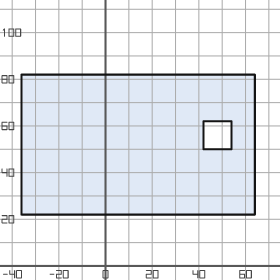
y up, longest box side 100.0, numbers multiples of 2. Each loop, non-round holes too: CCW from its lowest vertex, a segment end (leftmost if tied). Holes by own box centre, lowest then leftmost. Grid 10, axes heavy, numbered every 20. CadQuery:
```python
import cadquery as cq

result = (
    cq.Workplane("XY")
    .moveTo(-36.0, 22.0)
    .lineTo(64.0, 22.0)
    .lineTo(64.0, 82.0)
    .lineTo(-36.0, 82.0)
    .close()
    .moveTo(42.0, 50.0)
    .lineTo(54.0, 50.0)
    .lineTo(54.0, 62.0)
    .lineTo(42.0, 62.0)
    .close()
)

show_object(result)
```